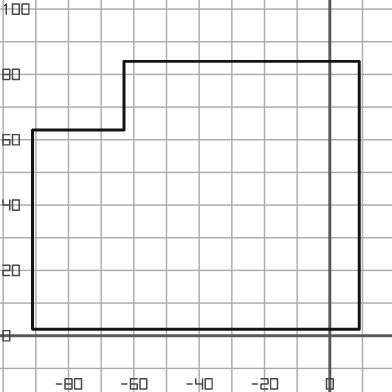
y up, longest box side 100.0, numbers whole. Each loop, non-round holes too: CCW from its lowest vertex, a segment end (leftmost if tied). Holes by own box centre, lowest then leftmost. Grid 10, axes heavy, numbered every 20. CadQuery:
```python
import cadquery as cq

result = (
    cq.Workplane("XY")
    .moveTo(-91.0, 2.0)
    .lineTo(9.0, 2.0)
    .lineTo(9.0, 84.0)
    .lineTo(-63.0, 84.0)
    .lineTo(-63.0, 63.0)
    .lineTo(-91.0, 63.0)
    .close()
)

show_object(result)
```